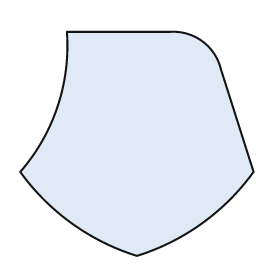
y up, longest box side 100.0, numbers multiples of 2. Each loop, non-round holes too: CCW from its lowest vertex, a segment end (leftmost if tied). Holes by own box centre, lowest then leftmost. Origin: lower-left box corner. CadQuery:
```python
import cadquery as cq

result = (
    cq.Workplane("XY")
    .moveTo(50.0, 0.0)
    .threePointArc((78.0, 14.0), (100.0, 36.0))
    .lineTo(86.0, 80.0)
    .threePointArc((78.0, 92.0), (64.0, 96.0))
    .lineTo(20.0, 96.0)
    .threePointArc((16.0, 64.0), (0.0, 36.0))
    .threePointArc((22.0, 14.0), (50.0, 0.0))
    .close()
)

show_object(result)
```